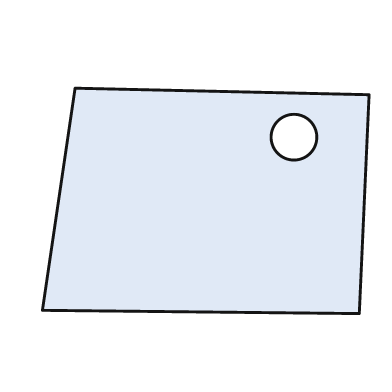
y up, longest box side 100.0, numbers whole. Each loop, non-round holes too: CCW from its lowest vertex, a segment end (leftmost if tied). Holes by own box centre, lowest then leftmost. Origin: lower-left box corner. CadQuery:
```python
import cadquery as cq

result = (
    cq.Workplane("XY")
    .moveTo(97.0, 0.0)
    .lineTo(100.0, 67.0)
    .lineTo(10.0, 69.0)
    .lineTo(0.0, 1.0)
    .close()
    .moveTo(77.0, 54.0)
    .circle(7.0)
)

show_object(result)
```